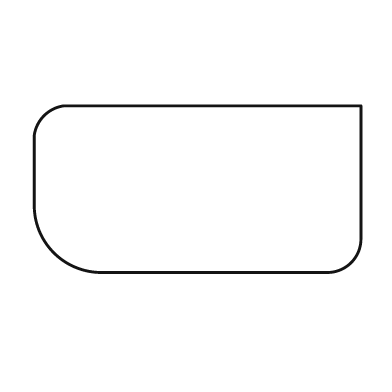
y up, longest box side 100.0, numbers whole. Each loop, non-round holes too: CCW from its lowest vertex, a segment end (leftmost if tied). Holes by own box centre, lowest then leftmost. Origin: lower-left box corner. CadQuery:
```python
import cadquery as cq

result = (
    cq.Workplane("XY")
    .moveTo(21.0, 0.0)
    .lineTo(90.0, 0.0)
    .threePointArc((97.0, 3.0), (100.0, 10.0))
    .lineTo(100.0, 51.0)
    .lineTo(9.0, 51.0)
    .threePointArc((3.0, 48.0), (0.0, 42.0))
    .lineTo(0.0, 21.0)
    .threePointArc((6.0, 6.0), (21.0, 0.0))
    .close()
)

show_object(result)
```